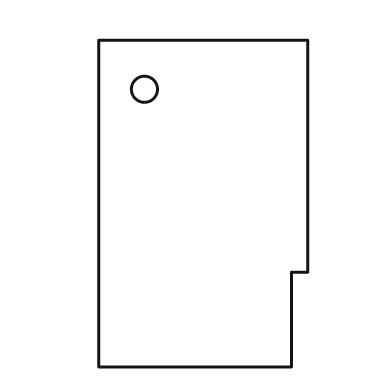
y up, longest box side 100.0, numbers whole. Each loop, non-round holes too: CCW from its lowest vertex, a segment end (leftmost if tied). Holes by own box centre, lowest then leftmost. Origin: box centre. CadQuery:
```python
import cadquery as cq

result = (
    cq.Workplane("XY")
    .moveTo(-32.0, -50.0)
    .lineTo(27.0, -50.0)
    .lineTo(27.0, -21.0)
    .lineTo(32.0, -21.0)
    .lineTo(32.0, 50.0)
    .lineTo(-32.0, 50.0)
    .close()
    .moveTo(-18.0, 35.0)
    .circle(4.0)
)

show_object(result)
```